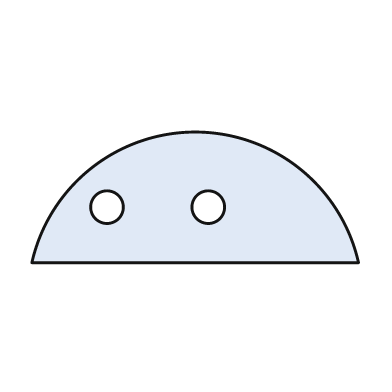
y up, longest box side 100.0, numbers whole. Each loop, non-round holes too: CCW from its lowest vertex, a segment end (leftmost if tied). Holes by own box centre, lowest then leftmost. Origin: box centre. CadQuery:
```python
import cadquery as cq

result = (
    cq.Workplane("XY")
    .moveTo(-50.0, -20.0)
    .lineTo(50.0, -20.0)
    .threePointArc((0.0, 20.0), (-50.0, -20.0))
    .close()
    .moveTo(-27.0, -3.0)
    .circle(5.0)
    .moveTo(4.0, -3.0)
    .circle(5.0)
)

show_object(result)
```